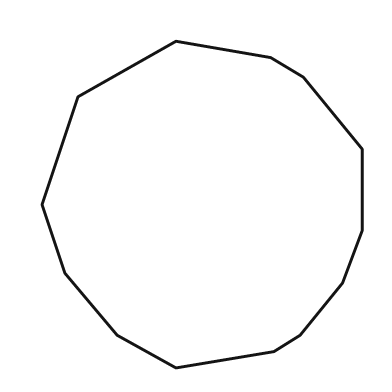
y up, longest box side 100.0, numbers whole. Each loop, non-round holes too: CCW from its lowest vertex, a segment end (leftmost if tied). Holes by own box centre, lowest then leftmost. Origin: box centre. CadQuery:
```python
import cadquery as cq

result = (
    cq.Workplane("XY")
    .moveTo(-8.0, -50.0)
    .lineTo(22.0, -45.0)
    .lineTo(30.0, -40.0)
    .lineTo(43.0, -24.0)
    .lineTo(49.0, -8.0)
    .lineTo(49.0, 17.0)
    .lineTo(31.0, 39.0)
    .lineTo(21.0, 45.0)
    .lineTo(-8.0, 50.0)
    .lineTo(-38.0, 33.0)
    .lineTo(-49.0, 0.0)
    .lineTo(-42.0, -21.0)
    .lineTo(-26.0, -40.0)
    .close()
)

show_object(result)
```